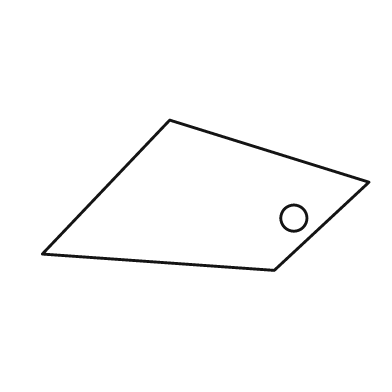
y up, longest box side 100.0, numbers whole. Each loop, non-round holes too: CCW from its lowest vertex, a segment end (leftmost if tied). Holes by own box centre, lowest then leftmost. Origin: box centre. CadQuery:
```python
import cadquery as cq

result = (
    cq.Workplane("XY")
    .moveTo(21.0, -23.0)
    .lineTo(50.0, 4.0)
    .lineTo(-11.0, 23.0)
    .lineTo(-50.0, -18.0)
    .close()
    .moveTo(27.0, -7.0)
    .circle(4.0)
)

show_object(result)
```